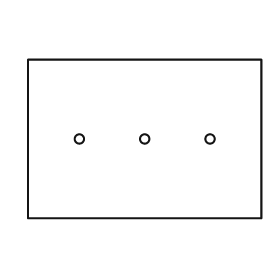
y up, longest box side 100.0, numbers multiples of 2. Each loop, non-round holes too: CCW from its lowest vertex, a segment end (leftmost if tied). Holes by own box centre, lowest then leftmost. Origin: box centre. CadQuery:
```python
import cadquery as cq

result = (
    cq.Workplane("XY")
    .moveTo(-50.0, -34.0)
    .lineTo(50.0, -34.0)
    .lineTo(50.0, 34.0)
    .lineTo(-50.0, 34.0)
    .close()
    .moveTo(-28.0, 0.0)
    .circle(2.0)
    .moveTo(0.0, 0.0)
    .circle(2.0)
    .moveTo(28.0, 0.0)
    .circle(2.0)
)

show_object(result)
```